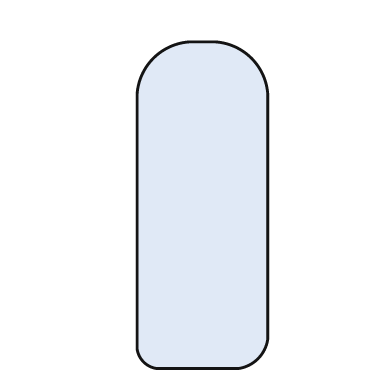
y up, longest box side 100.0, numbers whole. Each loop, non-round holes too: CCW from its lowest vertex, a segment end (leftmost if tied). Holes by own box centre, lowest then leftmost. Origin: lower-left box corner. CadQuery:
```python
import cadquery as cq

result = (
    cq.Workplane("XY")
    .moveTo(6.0, 0.0)
    .lineTo(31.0, 0.0)
    .threePointArc((37.0, 3.0), (40.0, 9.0))
    .lineTo(40.0, 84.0)
    .threePointArc((35.0, 95.0), (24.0, 100.0))
    .lineTo(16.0, 100.0)
    .threePointArc((5.0, 95.0), (0.0, 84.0))
    .lineTo(0.0, 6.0)
    .threePointArc((2.0, 2.0), (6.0, 0.0))
    .close()
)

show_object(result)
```